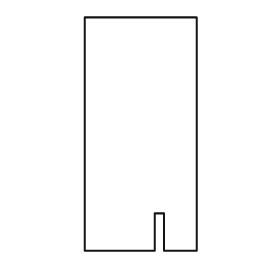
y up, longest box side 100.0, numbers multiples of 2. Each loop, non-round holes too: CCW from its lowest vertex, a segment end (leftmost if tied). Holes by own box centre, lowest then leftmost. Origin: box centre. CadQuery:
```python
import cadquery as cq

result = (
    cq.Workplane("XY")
    .moveTo(-24.0, -50.0)
    .lineTo(6.0, -50.0)
    .lineTo(6.0, -34.0)
    .lineTo(10.0, -34.0)
    .lineTo(10.0, -50.0)
    .lineTo(24.0, -50.0)
    .lineTo(24.0, 50.0)
    .lineTo(-24.0, 50.0)
    .close()
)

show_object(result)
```